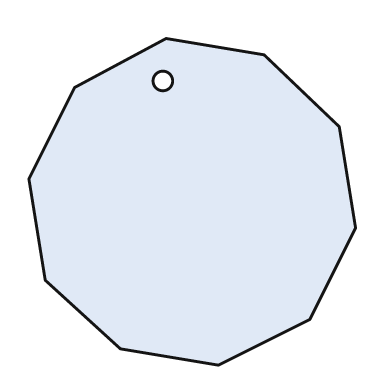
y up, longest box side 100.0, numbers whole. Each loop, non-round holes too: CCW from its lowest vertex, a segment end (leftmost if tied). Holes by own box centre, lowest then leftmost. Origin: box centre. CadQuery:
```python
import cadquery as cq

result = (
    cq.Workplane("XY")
    .moveTo(8.0, -50.0)
    .lineTo(36.0, -36.0)
    .lineTo(50.0, -8.0)
    .lineTo(45.0, 23.0)
    .lineTo(22.0, 45.0)
    .lineTo(-8.0, 50.0)
    .lineTo(-36.0, 35.0)
    .lineTo(-50.0, 7.0)
    .lineTo(-45.0, -24.0)
    .lineTo(-22.0, -45.0)
    .close()
    .moveTo(-9.0, 37.0)
    .circle(3.0)
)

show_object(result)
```